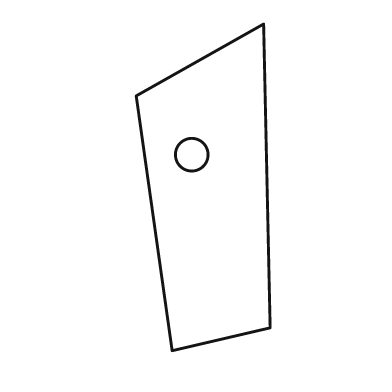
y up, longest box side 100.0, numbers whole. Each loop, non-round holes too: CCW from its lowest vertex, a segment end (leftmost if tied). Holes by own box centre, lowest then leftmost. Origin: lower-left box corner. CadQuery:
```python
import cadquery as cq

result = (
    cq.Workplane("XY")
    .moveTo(11.0, 0.0)
    .lineTo(41.0, 7.0)
    .lineTo(39.0, 100.0)
    .lineTo(0.0, 78.0)
    .close()
    .moveTo(17.0, 60.0)
    .circle(5.0)
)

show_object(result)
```